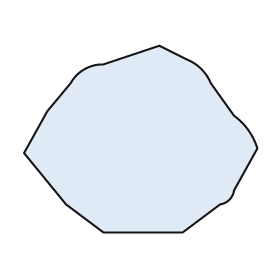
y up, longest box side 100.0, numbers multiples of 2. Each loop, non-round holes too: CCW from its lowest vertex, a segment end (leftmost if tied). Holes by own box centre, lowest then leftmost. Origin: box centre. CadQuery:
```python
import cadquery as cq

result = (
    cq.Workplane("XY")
    .moveTo(-16.0, -40.0)
    .lineTo(18.0, -40.0)
    .lineTo(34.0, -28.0)
    .threePointArc((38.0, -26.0), (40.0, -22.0))
    .lineTo(50.0, -4.0)
    .threePointArc((46.0, 4.0), (40.0, 10.0))
    .lineTo(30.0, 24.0)
    .threePointArc((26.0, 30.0), (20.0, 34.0))
    .lineTo(8.0, 40.0)
    .lineTo(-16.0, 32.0)
    .threePointArc((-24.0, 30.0), (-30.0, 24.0))
    .lineTo(-40.0, 12.0)
    .lineTo(-50.0, -6.0)
    .lineTo(-32.0, -28.0)
    .close()
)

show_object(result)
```